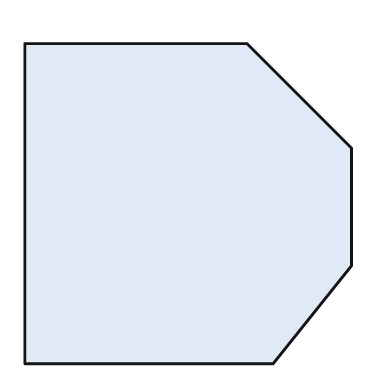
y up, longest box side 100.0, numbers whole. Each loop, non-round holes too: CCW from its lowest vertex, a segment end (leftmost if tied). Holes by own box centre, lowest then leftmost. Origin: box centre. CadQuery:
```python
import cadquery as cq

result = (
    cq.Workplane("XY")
    .moveTo(-50.0, -49.0)
    .lineTo(26.0, -49.0)
    .lineTo(50.0, -19.0)
    .lineTo(50.0, 17.0)
    .lineTo(18.0, 49.0)
    .lineTo(-50.0, 49.0)
    .close()
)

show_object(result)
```